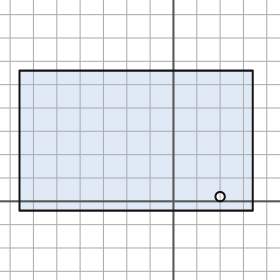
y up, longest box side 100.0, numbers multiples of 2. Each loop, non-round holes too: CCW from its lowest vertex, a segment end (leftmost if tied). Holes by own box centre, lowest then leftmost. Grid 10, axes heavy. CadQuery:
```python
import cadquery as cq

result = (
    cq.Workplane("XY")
    .moveTo(-66.0, -4.0)
    .lineTo(34.0, -4.0)
    .lineTo(34.0, 56.0)
    .lineTo(-66.0, 56.0)
    .close()
    .moveTo(20.0, 2.0)
    .circle(2.0)
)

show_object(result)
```